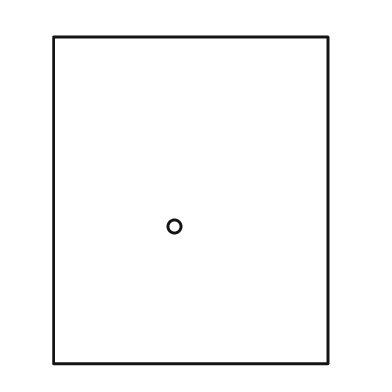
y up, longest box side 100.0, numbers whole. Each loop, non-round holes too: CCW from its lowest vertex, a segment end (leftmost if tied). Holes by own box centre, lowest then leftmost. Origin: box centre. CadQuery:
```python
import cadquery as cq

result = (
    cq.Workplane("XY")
    .moveTo(-42.0, -50.0)
    .lineTo(42.0, -50.0)
    .lineTo(42.0, 50.0)
    .lineTo(-42.0, 50.0)
    .close()
    .moveTo(-5.0, -8.0)
    .circle(2.0)
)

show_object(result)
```